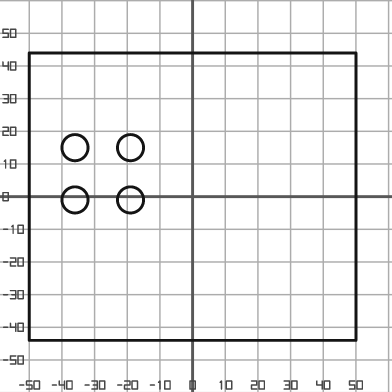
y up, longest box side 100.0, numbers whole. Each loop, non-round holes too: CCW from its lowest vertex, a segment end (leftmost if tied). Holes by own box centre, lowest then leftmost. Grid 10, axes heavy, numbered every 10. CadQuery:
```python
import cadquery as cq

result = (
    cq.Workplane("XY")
    .moveTo(-50.0, -44.0)
    .lineTo(50.0, -44.0)
    .lineTo(50.0, 44.0)
    .lineTo(-50.0, 44.0)
    .close()
    .moveTo(-36.0, -1.0)
    .circle(4.0)
    .moveTo(-19.0, -1.0)
    .circle(4.0)
    .moveTo(-36.0, 15.0)
    .circle(4.0)
    .moveTo(-19.0, 15.0)
    .circle(4.0)
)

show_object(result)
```